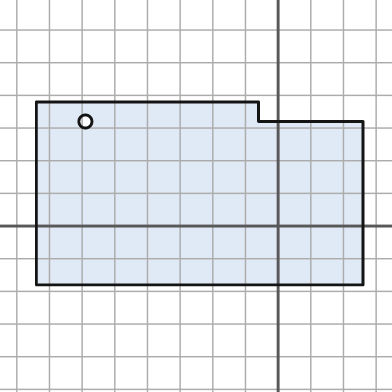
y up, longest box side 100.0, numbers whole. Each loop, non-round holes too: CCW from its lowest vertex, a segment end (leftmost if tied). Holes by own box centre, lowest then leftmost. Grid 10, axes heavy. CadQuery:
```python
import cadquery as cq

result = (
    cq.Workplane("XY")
    .moveTo(-74.0, -18.0)
    .lineTo(26.0, -18.0)
    .lineTo(26.0, 32.0)
    .lineTo(-6.0, 32.0)
    .lineTo(-6.0, 38.0)
    .lineTo(-74.0, 38.0)
    .close()
    .moveTo(-59.0, 32.0)
    .circle(2.0)
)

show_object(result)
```